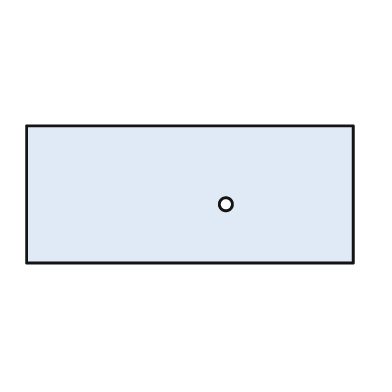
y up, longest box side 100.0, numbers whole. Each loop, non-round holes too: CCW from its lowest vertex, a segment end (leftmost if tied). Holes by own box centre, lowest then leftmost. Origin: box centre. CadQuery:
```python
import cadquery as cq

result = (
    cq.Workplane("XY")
    .moveTo(-50.0, -21.0)
    .lineTo(50.0, -21.0)
    .lineTo(50.0, 21.0)
    .lineTo(-50.0, 21.0)
    .close()
    .moveTo(11.0, -3.0)
    .circle(2.0)
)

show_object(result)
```